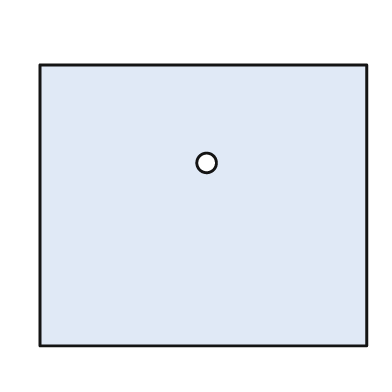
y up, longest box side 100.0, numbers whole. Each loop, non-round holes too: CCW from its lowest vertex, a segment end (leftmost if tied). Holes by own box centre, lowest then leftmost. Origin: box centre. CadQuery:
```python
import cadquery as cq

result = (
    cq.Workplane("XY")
    .moveTo(-50.0, -43.0)
    .lineTo(50.0, -43.0)
    .lineTo(50.0, 43.0)
    .lineTo(-50.0, 43.0)
    .close()
    .moveTo(1.0, 13.0)
    .circle(3.0)
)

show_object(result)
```